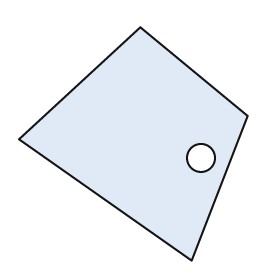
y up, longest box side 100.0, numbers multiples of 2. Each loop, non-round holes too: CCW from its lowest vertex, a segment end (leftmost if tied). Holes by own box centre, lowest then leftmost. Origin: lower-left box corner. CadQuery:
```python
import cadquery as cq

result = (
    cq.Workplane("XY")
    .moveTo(74.0, 0.0)
    .lineTo(98.0, 62.0)
    .lineTo(52.0, 100.0)
    .lineTo(0.0, 52.0)
    .close()
    .moveTo(78.0, 44.0)
    .circle(6.0)
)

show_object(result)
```